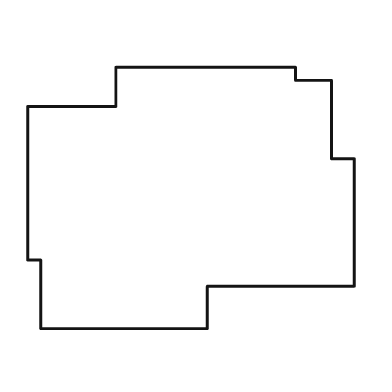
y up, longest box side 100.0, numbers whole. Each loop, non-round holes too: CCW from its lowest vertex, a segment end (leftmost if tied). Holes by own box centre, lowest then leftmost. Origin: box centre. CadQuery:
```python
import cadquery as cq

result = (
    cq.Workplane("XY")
    .moveTo(-46.0, -40.0)
    .lineTo(5.0, -40.0)
    .lineTo(5.0, -27.0)
    .lineTo(50.0, -27.0)
    .lineTo(50.0, 12.0)
    .lineTo(43.0, 12.0)
    .lineTo(43.0, 36.0)
    .lineTo(32.0, 36.0)
    .lineTo(32.0, 40.0)
    .lineTo(-23.0, 40.0)
    .lineTo(-23.0, 28.0)
    .lineTo(-50.0, 28.0)
    .lineTo(-50.0, -19.0)
    .lineTo(-46.0, -19.0)
    .close()
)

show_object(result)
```